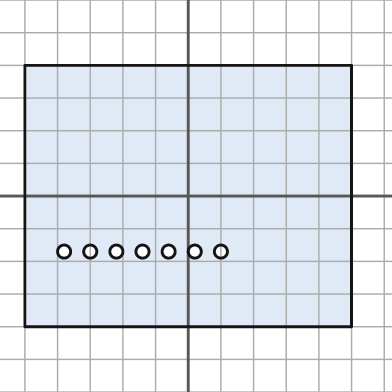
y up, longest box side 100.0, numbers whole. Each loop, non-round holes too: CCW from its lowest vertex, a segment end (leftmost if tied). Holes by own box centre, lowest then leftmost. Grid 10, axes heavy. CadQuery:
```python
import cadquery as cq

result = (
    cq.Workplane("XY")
    .moveTo(-50.0, -40.0)
    .lineTo(50.0, -40.0)
    .lineTo(50.0, 40.0)
    .lineTo(-50.0, 40.0)
    .close()
    .moveTo(-38.0, -17.0)
    .circle(2.0)
    .moveTo(-30.0, -17.0)
    .circle(2.0)
    .moveTo(-22.0, -17.0)
    .circle(2.0)
    .moveTo(-14.0, -17.0)
    .circle(2.0)
    .moveTo(-6.0, -17.0)
    .circle(2.0)
    .moveTo(2.0, -17.0)
    .circle(2.0)
    .moveTo(10.0, -17.0)
    .circle(2.0)
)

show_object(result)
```